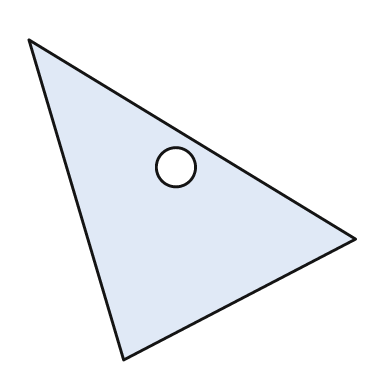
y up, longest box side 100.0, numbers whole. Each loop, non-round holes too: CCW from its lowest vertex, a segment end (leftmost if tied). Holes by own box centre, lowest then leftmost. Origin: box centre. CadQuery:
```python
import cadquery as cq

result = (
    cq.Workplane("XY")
    .moveTo(-21.0, -49.0)
    .lineTo(50.0, -12.0)
    .lineTo(-50.0, 49.0)
    .close()
    .moveTo(-5.0, 10.0)
    .circle(6.0)
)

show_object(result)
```